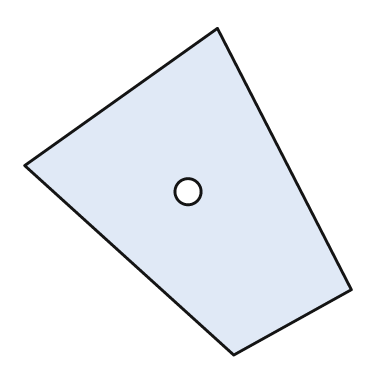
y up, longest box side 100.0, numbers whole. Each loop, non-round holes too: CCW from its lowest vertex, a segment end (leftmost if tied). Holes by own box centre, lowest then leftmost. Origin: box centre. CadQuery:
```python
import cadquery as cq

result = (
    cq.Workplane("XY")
    .moveTo(14.0, -50.0)
    .lineTo(50.0, -30.0)
    .lineTo(9.0, 50.0)
    .lineTo(-50.0, 8.0)
    .close()
    .moveTo(0.0, 0.0)
    .circle(4.0)
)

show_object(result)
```